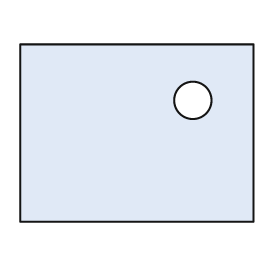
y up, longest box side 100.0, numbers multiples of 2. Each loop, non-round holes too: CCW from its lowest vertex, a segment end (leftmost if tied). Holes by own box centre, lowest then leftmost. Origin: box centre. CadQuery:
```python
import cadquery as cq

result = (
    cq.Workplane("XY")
    .moveTo(-50.0, -38.0)
    .lineTo(50.0, -38.0)
    .lineTo(50.0, 38.0)
    .lineTo(-50.0, 38.0)
    .close()
    .moveTo(24.0, 14.0)
    .circle(8.0)
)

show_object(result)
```